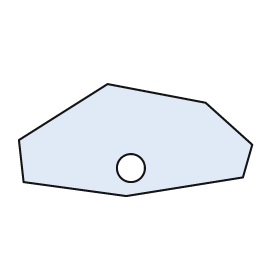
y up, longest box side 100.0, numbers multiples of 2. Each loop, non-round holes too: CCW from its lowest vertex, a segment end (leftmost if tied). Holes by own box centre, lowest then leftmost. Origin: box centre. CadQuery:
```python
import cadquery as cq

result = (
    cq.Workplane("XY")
    .moveTo(-4.0, -24.0)
    .lineTo(46.0, -16.0)
    .lineTo(50.0, -2.0)
    .lineTo(30.0, 16.0)
    .lineTo(-12.0, 24.0)
    .lineTo(-50.0, 0.0)
    .lineTo(-48.0, -18.0)
    .close()
    .moveTo(-2.0, -12.0)
    .circle(6.0)
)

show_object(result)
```